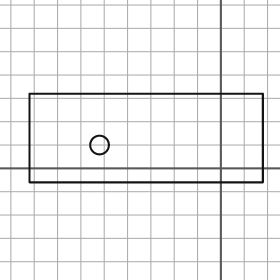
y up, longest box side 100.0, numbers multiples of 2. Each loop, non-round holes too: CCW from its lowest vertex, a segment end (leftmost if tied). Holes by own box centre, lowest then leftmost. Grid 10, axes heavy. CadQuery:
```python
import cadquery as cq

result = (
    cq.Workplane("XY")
    .moveTo(-82.0, -6.0)
    .lineTo(18.0, -6.0)
    .lineTo(18.0, 32.0)
    .lineTo(-82.0, 32.0)
    .close()
    .moveTo(-52.0, 10.0)
    .circle(4.0)
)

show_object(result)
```